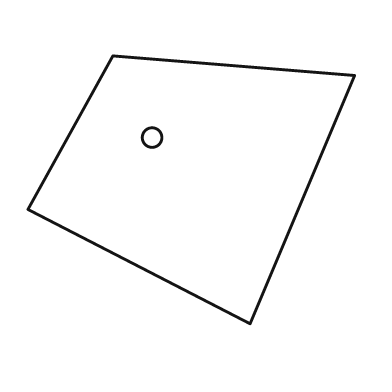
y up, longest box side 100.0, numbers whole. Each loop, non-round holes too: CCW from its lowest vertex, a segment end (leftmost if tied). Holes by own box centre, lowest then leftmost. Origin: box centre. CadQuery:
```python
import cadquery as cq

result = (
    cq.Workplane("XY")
    .moveTo(18.0, -41.0)
    .lineTo(50.0, 35.0)
    .lineTo(-24.0, 41.0)
    .lineTo(-50.0, -6.0)
    .close()
    .moveTo(-12.0, 16.0)
    .circle(3.0)
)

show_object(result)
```